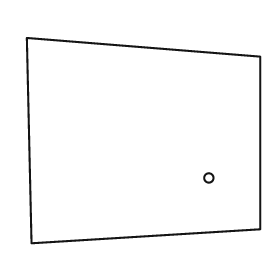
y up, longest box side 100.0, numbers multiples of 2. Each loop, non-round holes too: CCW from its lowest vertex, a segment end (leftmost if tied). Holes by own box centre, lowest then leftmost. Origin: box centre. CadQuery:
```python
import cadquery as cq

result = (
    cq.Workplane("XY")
    .moveTo(-48.0, -44.0)
    .lineTo(50.0, -38.0)
    .lineTo(50.0, 36.0)
    .lineTo(-50.0, 44.0)
    .close()
    .moveTo(28.0, -16.0)
    .circle(2.0)
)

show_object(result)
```